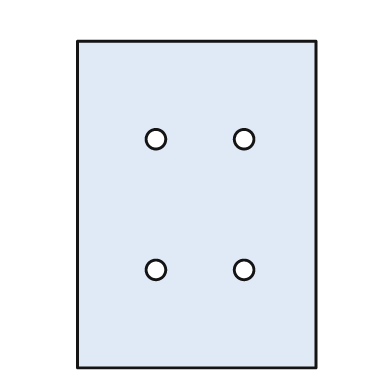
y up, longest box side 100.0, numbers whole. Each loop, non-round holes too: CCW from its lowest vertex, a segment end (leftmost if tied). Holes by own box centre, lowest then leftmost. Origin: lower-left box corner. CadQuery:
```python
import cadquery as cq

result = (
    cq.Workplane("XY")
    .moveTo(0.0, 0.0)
    .lineTo(73.0, 0.0)
    .lineTo(73.0, 100.0)
    .lineTo(0.0, 100.0)
    .close()
    .moveTo(24.0, 30.0)
    .circle(3.0)
    .moveTo(51.0, 30.0)
    .circle(3.0)
    .moveTo(24.0, 70.0)
    .circle(3.0)
    .moveTo(51.0, 70.0)
    .circle(3.0)
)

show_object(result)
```